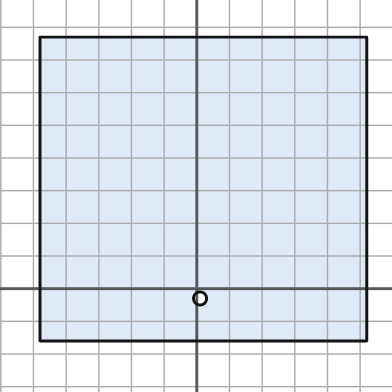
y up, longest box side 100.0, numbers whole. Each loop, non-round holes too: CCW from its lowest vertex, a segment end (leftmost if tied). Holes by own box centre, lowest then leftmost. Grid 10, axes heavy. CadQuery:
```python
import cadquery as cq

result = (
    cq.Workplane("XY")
    .moveTo(-48.0, -16.0)
    .lineTo(52.0, -16.0)
    .lineTo(52.0, 77.0)
    .lineTo(-48.0, 77.0)
    .close()
    .moveTo(1.0, -3.0)
    .circle(2.0)
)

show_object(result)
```